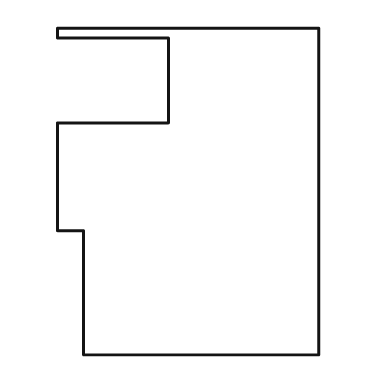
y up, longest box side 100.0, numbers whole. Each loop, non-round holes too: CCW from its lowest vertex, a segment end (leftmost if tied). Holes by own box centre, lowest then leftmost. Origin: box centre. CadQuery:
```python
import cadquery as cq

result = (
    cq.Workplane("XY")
    .moveTo(-32.0, -50.0)
    .lineTo(40.0, -50.0)
    .lineTo(40.0, 50.0)
    .lineTo(-40.0, 50.0)
    .lineTo(-40.0, 47.0)
    .lineTo(-6.0, 47.0)
    .lineTo(-6.0, 21.0)
    .lineTo(-40.0, 21.0)
    .lineTo(-40.0, -12.0)
    .lineTo(-32.0, -12.0)
    .close()
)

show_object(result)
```